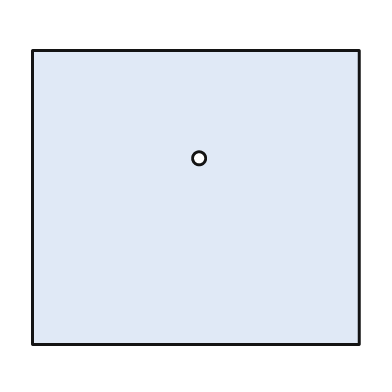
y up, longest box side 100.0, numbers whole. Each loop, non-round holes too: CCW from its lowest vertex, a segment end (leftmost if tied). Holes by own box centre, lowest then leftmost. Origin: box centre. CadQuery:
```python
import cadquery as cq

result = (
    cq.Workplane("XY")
    .moveTo(-50.0, -45.0)
    .lineTo(50.0, -45.0)
    .lineTo(50.0, 45.0)
    .lineTo(-50.0, 45.0)
    .close()
    .moveTo(1.0, 12.0)
    .circle(2.0)
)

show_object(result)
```